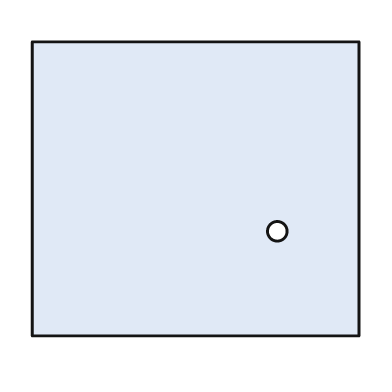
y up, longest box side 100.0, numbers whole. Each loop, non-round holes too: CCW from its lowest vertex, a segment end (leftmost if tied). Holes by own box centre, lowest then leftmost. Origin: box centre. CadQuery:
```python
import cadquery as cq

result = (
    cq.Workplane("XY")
    .moveTo(-50.0, -45.0)
    .lineTo(50.0, -45.0)
    .lineTo(50.0, 45.0)
    .lineTo(-50.0, 45.0)
    .close()
    .moveTo(25.0, -13.0)
    .circle(3.0)
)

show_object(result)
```